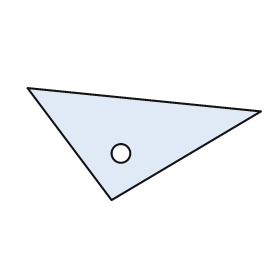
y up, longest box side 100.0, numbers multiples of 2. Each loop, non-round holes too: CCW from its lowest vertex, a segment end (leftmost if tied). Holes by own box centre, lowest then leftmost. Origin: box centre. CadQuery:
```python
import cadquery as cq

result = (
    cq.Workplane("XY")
    .moveTo(-14.0, -24.0)
    .lineTo(50.0, 14.0)
    .lineTo(-50.0, 24.0)
    .close()
    .moveTo(-10.0, -4.0)
    .circle(4.0)
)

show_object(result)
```